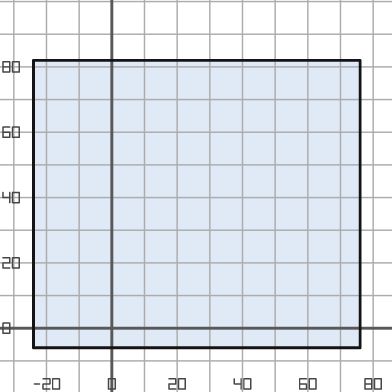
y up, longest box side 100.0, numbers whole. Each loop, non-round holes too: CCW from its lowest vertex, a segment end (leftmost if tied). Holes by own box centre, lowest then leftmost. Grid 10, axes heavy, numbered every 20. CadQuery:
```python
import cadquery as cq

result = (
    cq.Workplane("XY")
    .moveTo(-24.0, -6.0)
    .lineTo(76.0, -6.0)
    .lineTo(76.0, 82.0)
    .lineTo(-24.0, 82.0)
    .close()
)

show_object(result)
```